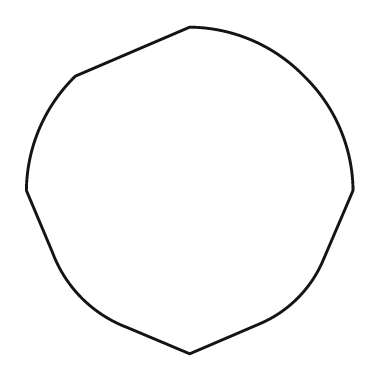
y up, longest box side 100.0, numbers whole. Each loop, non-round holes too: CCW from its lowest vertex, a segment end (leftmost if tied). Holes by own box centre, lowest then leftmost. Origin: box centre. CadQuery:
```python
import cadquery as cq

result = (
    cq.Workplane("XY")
    .moveTo(0.0, -50.0)
    .lineTo(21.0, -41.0)
    .threePointArc((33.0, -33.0), (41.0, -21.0))
    .lineTo(50.0, 0.0)
    .threePointArc((46.0, 19.0), (35.0, 35.0))
    .threePointArc((19.0, 46.0), (0.0, 50.0))
    .lineTo(-35.0, 35.0)
    .threePointArc((-46.0, 19.0), (-50.0, 0.0))
    .lineTo(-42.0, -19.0)
    .threePointArc((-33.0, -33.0), (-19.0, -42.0))
    .close()
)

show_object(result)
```